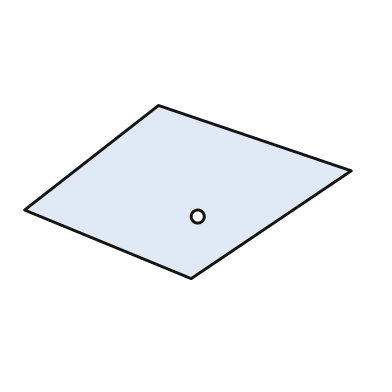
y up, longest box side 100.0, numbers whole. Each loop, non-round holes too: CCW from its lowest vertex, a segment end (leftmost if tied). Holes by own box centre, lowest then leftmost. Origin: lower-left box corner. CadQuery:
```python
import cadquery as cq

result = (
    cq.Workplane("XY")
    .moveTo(51.0, 0.0)
    .lineTo(100.0, 33.0)
    .lineTo(41.0, 53.0)
    .lineTo(0.0, 21.0)
    .close()
    .moveTo(53.0, 19.0)
    .circle(2.0)
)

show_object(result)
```